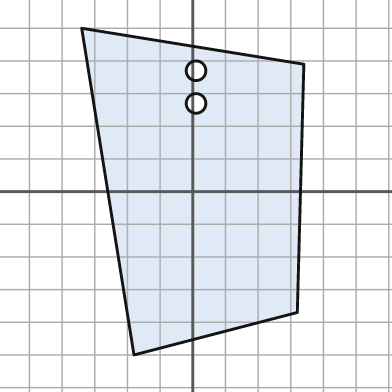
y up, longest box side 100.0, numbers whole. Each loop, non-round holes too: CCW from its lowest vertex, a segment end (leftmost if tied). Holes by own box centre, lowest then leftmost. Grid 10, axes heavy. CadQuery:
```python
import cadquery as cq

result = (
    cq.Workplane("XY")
    .moveTo(-18.0, -50.0)
    .lineTo(32.0, -37.0)
    .lineTo(34.0, 39.0)
    .lineTo(-34.0, 50.0)
    .close()
    .moveTo(1.0, 27.0)
    .circle(3.0)
    .moveTo(1.0, 37.0)
    .circle(3.0)
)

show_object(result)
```